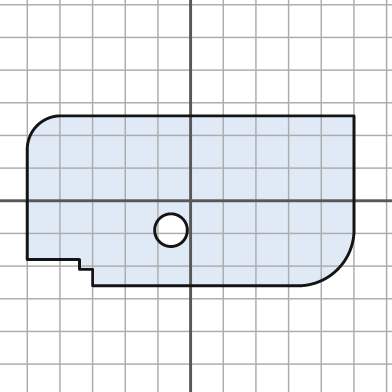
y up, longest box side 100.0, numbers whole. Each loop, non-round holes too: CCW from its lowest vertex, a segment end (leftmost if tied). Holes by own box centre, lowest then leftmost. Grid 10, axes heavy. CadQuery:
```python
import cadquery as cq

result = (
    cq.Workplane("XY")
    .moveTo(-30.0, -26.0)
    .lineTo(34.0, -26.0)
    .threePointArc((45.0, -21.0), (50.0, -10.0))
    .lineTo(50.0, 26.0)
    .lineTo(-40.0, 26.0)
    .threePointArc((-47.0, 23.0), (-50.0, 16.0))
    .lineTo(-50.0, -18.0)
    .lineTo(-34.0, -18.0)
    .lineTo(-34.0, -21.0)
    .lineTo(-30.0, -21.0)
    .close()
    .moveTo(-6.0, -9.0)
    .circle(5.0)
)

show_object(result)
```